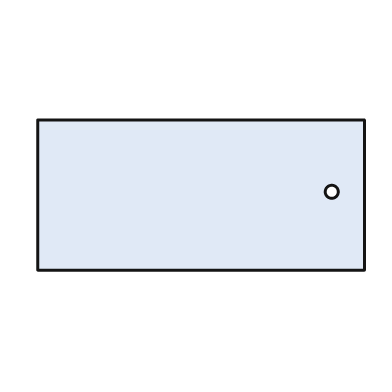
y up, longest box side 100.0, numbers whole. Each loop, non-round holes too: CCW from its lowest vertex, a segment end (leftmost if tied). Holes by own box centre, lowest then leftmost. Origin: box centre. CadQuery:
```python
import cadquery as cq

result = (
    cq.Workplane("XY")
    .moveTo(-50.0, -23.0)
    .lineTo(50.0, -23.0)
    .lineTo(50.0, 23.0)
    .lineTo(-50.0, 23.0)
    .close()
    .moveTo(40.0, 1.0)
    .circle(2.0)
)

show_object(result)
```